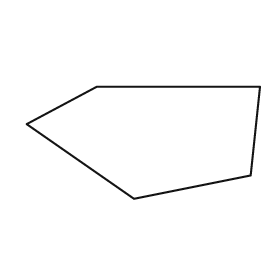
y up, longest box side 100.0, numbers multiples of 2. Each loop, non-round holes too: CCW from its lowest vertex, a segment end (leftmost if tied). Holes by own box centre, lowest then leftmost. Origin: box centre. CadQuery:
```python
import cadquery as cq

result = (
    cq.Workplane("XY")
    .moveTo(-4.0, -24.0)
    .lineTo(46.0, -14.0)
    .lineTo(50.0, 24.0)
    .lineTo(-20.0, 24.0)
    .lineTo(-50.0, 8.0)
    .close()
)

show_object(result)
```